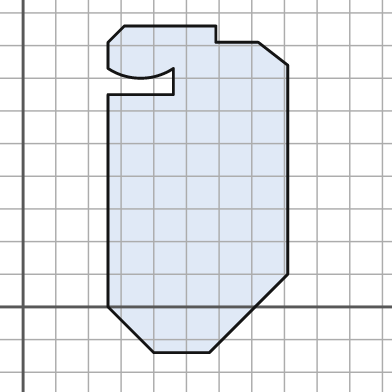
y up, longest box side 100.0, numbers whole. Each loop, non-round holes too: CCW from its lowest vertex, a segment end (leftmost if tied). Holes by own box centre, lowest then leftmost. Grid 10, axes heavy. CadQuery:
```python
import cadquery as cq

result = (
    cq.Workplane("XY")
    .moveTo(40.0, -14.0)
    .lineTo(57.0, -14.0)
    .lineTo(81.0, 10.0)
    .lineTo(81.0, 74.0)
    .lineTo(72.0, 81.0)
    .lineTo(59.0, 81.0)
    .lineTo(59.0, 86.0)
    .lineTo(31.0, 86.0)
    .lineTo(26.0, 81.0)
    .lineTo(26.0, 73.0)
    .threePointArc((36.0, 70.0), (46.0, 73.0))
    .lineTo(46.0, 65.0)
    .lineTo(26.0, 65.0)
    .lineTo(26.0, 0.0)
    .close()
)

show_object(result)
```